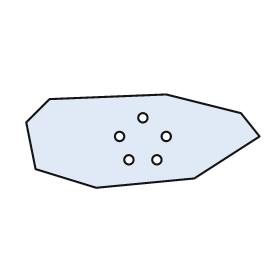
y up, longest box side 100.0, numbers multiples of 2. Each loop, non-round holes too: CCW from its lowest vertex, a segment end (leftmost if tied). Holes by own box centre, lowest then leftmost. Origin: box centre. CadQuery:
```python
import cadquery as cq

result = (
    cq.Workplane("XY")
    .moveTo(-20.0, -20.0)
    .lineTo(22.0, -16.0)
    .lineTo(50.0, 2.0)
    .lineTo(42.0, 12.0)
    .lineTo(10.0, 20.0)
    .lineTo(-40.0, 18.0)
    .lineTo(-50.0, 8.0)
    .lineTo(-46.0, -12.0)
    .close()
    .moveTo(-6.0, -8.0)
    .circle(2.0)
    .moveTo(6.0, -8.0)
    .circle(2.0)
    .moveTo(-10.0, 2.0)
    .circle(2.0)
    .moveTo(10.0, 2.0)
    .circle(2.0)
    .moveTo(0.0, 10.0)
    .circle(2.0)
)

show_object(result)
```